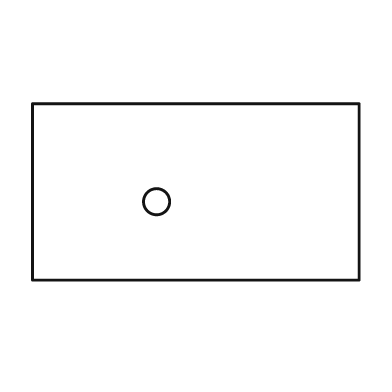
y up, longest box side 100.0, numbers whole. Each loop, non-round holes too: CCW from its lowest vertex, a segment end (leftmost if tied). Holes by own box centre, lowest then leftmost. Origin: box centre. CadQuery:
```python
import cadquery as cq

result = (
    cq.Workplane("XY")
    .moveTo(-50.0, -27.0)
    .lineTo(50.0, -27.0)
    .lineTo(50.0, 27.0)
    .lineTo(-50.0, 27.0)
    .close()
    .moveTo(-12.0, -3.0)
    .circle(4.0)
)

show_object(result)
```